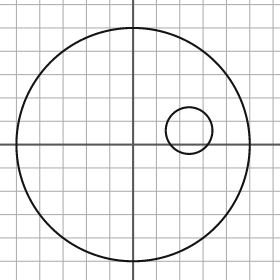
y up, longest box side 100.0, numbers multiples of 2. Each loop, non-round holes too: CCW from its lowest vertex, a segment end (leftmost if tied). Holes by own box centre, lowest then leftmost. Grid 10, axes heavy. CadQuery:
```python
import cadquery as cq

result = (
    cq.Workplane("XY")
    .moveTo(0.0, 0.0)
    .circle(50.0)
    .moveTo(24.0, 6.0)
    .circle(10.0)
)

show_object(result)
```